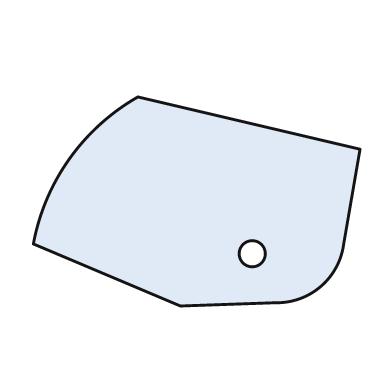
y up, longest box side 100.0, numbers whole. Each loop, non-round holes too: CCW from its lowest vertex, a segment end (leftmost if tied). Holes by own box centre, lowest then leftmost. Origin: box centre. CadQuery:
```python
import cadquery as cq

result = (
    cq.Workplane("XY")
    .moveTo(-5.0, -32.0)
    .lineTo(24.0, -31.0)
    .threePointArc((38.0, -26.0), (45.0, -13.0))
    .lineTo(50.0, 16.0)
    .lineTo(-18.0, 32.0)
    .threePointArc((-39.0, 13.0), (-50.0, -13.0))
    .close()
    .moveTo(17.0, -16.0)
    .circle(4.0)
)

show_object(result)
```